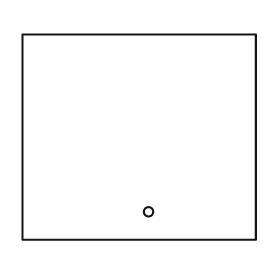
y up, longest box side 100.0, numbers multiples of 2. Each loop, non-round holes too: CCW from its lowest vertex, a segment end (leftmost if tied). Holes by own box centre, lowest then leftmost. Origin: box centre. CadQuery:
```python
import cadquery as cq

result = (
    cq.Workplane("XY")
    .moveTo(-50.0, -44.0)
    .lineTo(50.0, -44.0)
    .lineTo(50.0, 44.0)
    .lineTo(-50.0, 44.0)
    .close()
    .moveTo(4.0, -32.0)
    .circle(2.0)
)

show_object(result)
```